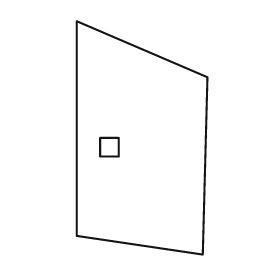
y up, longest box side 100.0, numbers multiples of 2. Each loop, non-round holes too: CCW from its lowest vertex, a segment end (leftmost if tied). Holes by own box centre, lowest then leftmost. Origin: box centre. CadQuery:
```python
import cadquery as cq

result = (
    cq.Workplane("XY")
    .moveTo(26.0, -50.0)
    .lineTo(28.0, 26.0)
    .lineTo(-28.0, 50.0)
    .lineTo(-28.0, -42.0)
    .close()
    .moveTo(-18.0, -8.0)
    .lineTo(-10.0, -8.0)
    .lineTo(-10.0, 0.0)
    .lineTo(-18.0, 0.0)
    .close()
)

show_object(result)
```